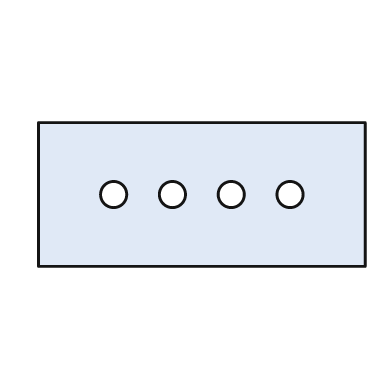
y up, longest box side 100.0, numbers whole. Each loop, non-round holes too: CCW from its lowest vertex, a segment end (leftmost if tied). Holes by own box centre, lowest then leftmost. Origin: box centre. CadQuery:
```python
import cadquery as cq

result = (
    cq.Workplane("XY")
    .moveTo(-50.0, -22.0)
    .lineTo(50.0, -22.0)
    .lineTo(50.0, 22.0)
    .lineTo(-50.0, 22.0)
    .close()
    .moveTo(-27.0, 0.0)
    .circle(4.0)
    .moveTo(-9.0, 0.0)
    .circle(4.0)
    .moveTo(9.0, 0.0)
    .circle(4.0)
    .moveTo(27.0, 0.0)
    .circle(4.0)
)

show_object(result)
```